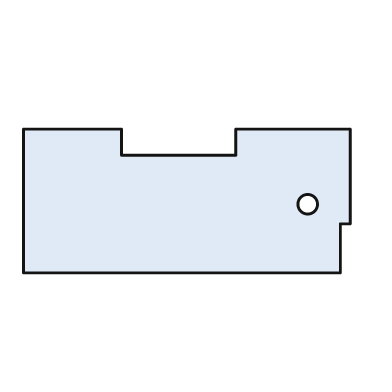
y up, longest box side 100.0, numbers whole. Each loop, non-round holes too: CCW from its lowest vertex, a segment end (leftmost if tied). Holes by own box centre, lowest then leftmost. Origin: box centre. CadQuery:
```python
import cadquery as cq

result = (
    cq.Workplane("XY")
    .moveTo(-50.0, -22.0)
    .lineTo(47.0, -22.0)
    .lineTo(47.0, -7.0)
    .lineTo(50.0, -7.0)
    .lineTo(50.0, 22.0)
    .lineTo(15.0, 22.0)
    .lineTo(15.0, 14.0)
    .lineTo(-20.0, 14.0)
    .lineTo(-20.0, 22.0)
    .lineTo(-50.0, 22.0)
    .close()
    .moveTo(37.0, -1.0)
    .circle(3.0)
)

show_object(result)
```